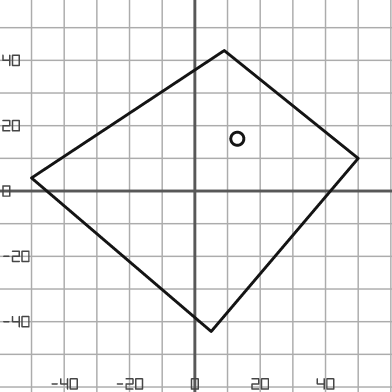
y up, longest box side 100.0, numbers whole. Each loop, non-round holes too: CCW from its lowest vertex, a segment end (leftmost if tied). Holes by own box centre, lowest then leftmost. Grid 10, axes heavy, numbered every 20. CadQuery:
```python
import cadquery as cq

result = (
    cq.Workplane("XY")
    .moveTo(5.0, -43.0)
    .lineTo(50.0, 10.0)
    .lineTo(9.0, 43.0)
    .lineTo(-50.0, 4.0)
    .close()
    .moveTo(13.0, 16.0)
    .circle(2.0)
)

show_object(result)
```